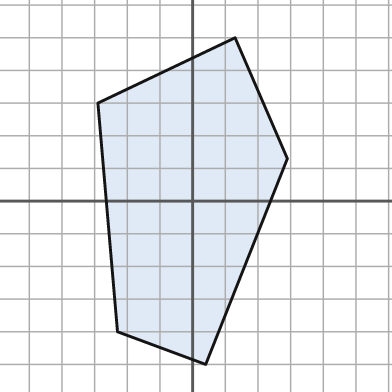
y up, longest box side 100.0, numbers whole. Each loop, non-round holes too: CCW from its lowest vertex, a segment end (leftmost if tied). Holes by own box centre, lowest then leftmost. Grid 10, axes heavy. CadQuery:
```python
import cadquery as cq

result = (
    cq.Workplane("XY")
    .moveTo(4.0, -50.0)
    .lineTo(29.0, 13.0)
    .lineTo(13.0, 50.0)
    .lineTo(-29.0, 30.0)
    .lineTo(-23.0, -40.0)
    .close()
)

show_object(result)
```